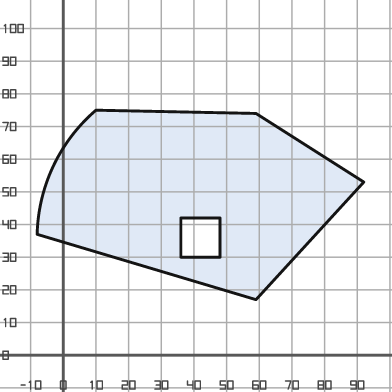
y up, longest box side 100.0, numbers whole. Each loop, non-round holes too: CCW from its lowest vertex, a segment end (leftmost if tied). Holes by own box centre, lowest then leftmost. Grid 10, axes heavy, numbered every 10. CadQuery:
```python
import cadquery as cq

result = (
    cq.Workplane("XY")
    .moveTo(59.0, 17.0)
    .lineTo(92.0, 53.0)
    .lineTo(59.0, 74.0)
    .lineTo(10.0, 75.0)
    .threePointArc((-3.0, 58.0), (-8.0, 37.0))
    .close()
    .moveTo(36.0, 30.0)
    .lineTo(48.0, 30.0)
    .lineTo(48.0, 42.0)
    .lineTo(36.0, 42.0)
    .close()
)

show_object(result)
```